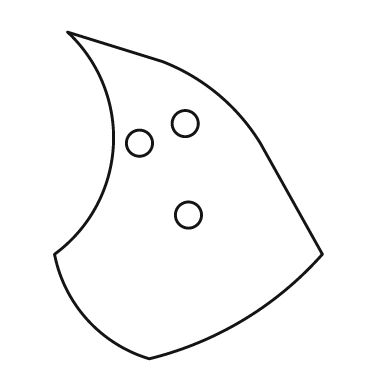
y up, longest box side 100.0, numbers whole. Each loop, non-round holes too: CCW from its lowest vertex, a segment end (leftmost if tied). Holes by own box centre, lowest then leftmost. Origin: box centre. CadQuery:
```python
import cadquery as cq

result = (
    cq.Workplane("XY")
    .moveTo(-12.0, -50.0)
    .threePointArc((17.0, -38.0), (41.0, -18.0))
    .lineTo(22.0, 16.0)
    .threePointArc((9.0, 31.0), (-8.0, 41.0))
    .lineTo(-37.0, 50.0)
    .threePointArc((-23.0, 15.0), (-41.0, -18.0))
    .threePointArc((-31.0, -38.0), (-12.0, -50.0))
    .close()
    .moveTo(0.0, -6.0)
    .circle(4.0)
    .moveTo(-15.0, 16.0)
    .circle(4.0)
    .moveTo(-1.0, 22.0)
    .circle(4.0)
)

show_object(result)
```